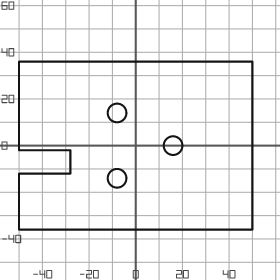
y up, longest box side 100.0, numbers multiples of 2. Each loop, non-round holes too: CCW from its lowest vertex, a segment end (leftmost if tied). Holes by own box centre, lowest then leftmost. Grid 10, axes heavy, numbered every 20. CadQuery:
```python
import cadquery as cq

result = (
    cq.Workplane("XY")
    .moveTo(-50.0, -36.0)
    .lineTo(50.0, -36.0)
    .lineTo(50.0, 36.0)
    .lineTo(-50.0, 36.0)
    .lineTo(-50.0, -2.0)
    .lineTo(-28.0, -2.0)
    .lineTo(-28.0, -12.0)
    .lineTo(-50.0, -12.0)
    .close()
    .moveTo(-8.0, -14.0)
    .circle(4.0)
    .moveTo(16.0, 0.0)
    .circle(4.0)
    .moveTo(-8.0, 14.0)
    .circle(4.0)
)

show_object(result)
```